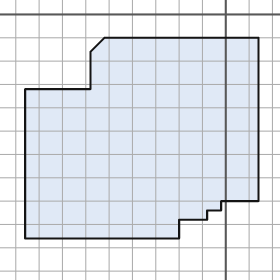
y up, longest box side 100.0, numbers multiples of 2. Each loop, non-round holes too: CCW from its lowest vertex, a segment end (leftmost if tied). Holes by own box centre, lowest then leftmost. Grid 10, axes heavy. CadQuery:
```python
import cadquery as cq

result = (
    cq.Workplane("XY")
    .moveTo(-86.0, -96.0)
    .lineTo(-20.0, -96.0)
    .lineTo(-20.0, -88.0)
    .lineTo(-8.0, -88.0)
    .lineTo(-8.0, -84.0)
    .lineTo(-2.0, -84.0)
    .lineTo(-2.0, -80.0)
    .lineTo(14.0, -80.0)
    .lineTo(14.0, -10.0)
    .lineTo(-52.0, -10.0)
    .lineTo(-58.0, -16.0)
    .lineTo(-58.0, -32.0)
    .lineTo(-86.0, -32.0)
    .close()
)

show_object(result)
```